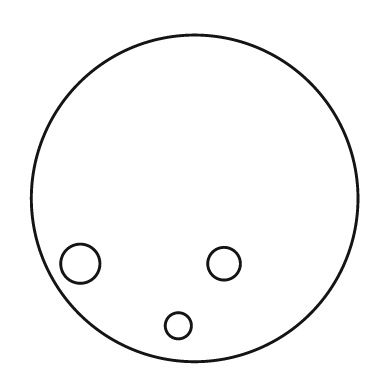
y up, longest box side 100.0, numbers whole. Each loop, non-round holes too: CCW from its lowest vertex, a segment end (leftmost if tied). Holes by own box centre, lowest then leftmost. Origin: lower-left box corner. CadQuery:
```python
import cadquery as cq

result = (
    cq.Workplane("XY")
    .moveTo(50.0, 50.0)
    .circle(50.0)
    .moveTo(45.0, 11.0)
    .circle(4.0)
    .moveTo(15.0, 30.0)
    .circle(6.0)
    .moveTo(59.0, 30.0)
    .circle(5.0)
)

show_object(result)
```